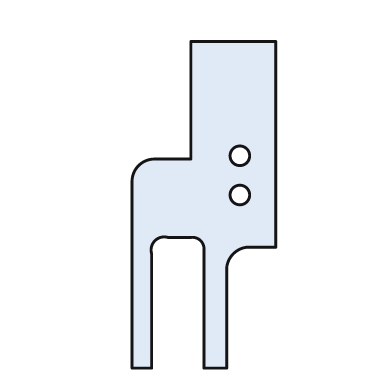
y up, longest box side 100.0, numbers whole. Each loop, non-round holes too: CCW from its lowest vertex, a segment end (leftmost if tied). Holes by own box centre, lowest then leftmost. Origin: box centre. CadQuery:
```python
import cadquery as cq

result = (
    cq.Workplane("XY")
    .moveTo(-22.0, -50.0)
    .lineTo(-16.0, -50.0)
    .lineTo(-16.0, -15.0)
    .threePointArc((-15.0, -11.0), (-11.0, -10.0))
    .lineTo(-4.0, -10.0)
    .threePointArc((-1.0, -11.0), (0.0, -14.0))
    .lineTo(0.0, -50.0)
    .lineTo(7.0, -50.0)
    .lineTo(7.0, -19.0)
    .threePointArc((9.0, -15.0), (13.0, -13.0))
    .lineTo(22.0, -13.0)
    .lineTo(22.0, 50.0)
    .lineTo(-4.0, 50.0)
    .lineTo(-4.0, 14.0)
    .lineTo(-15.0, 14.0)
    .threePointArc((-20.0, 12.0), (-22.0, 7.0))
    .close()
    .moveTo(11.0, 3.0)
    .circle(3.0)
    .moveTo(11.0, 15.0)
    .circle(3.0)
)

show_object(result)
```